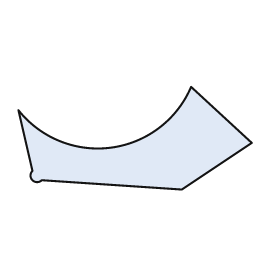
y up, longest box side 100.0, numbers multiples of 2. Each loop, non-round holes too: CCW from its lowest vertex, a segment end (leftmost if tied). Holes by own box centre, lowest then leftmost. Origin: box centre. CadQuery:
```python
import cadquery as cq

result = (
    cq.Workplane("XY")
    .moveTo(20.0, -22.0)
    .lineTo(50.0, -2.0)
    .lineTo(24.0, 22.0)
    .threePointArc((-10.0, -4.0), (-50.0, 12.0))
    .lineTo(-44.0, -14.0)
    .threePointArc((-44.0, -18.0), (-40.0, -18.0))
    .close()
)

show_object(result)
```